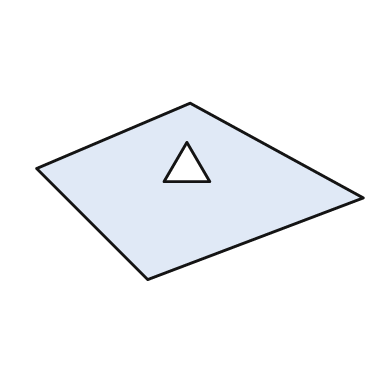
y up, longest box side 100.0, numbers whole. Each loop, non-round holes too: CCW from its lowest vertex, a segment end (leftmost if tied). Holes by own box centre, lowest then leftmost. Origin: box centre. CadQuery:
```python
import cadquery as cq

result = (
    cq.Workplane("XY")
    .moveTo(-16.0, -27.0)
    .lineTo(50.0, -2.0)
    .lineTo(-3.0, 27.0)
    .lineTo(-50.0, 7.0)
    .close()
    .moveTo(-11.0, 3.0)
    .lineTo(3.0, 3.0)
    .lineTo(-4.0, 15.0)
    .close()
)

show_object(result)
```